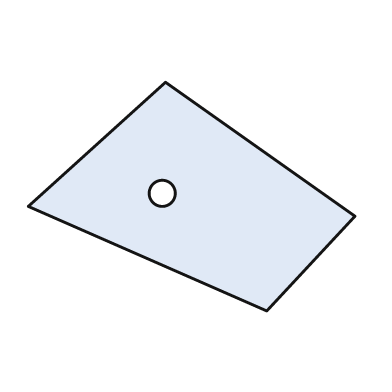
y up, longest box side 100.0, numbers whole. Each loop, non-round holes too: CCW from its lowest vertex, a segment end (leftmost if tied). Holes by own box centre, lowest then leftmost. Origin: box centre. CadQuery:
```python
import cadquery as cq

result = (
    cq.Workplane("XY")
    .moveTo(23.0, -35.0)
    .lineTo(50.0, -6.0)
    .lineTo(-8.0, 35.0)
    .lineTo(-50.0, -3.0)
    .close()
    .moveTo(-9.0, 1.0)
    .circle(4.0)
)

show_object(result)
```